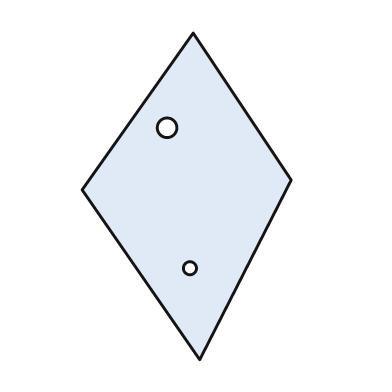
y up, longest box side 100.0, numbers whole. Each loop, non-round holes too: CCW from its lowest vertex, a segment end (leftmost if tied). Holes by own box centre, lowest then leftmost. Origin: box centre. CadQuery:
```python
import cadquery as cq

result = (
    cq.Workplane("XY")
    .moveTo(4.0, -50.0)
    .lineTo(32.0, 5.0)
    .lineTo(2.0, 50.0)
    .lineTo(-32.0, 2.0)
    .close()
    .moveTo(1.0, -22.0)
    .circle(2.0)
    .moveTo(-6.0, 21.0)
    .circle(3.0)
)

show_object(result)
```